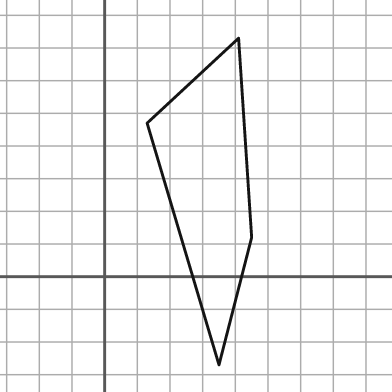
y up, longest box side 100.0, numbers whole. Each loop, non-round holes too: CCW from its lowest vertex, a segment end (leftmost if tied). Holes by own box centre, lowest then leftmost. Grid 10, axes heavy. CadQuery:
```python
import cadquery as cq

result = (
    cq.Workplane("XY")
    .moveTo(35.0, -27.0)
    .lineTo(45.0, 12.0)
    .lineTo(41.0, 73.0)
    .lineTo(13.0, 47.0)
    .close()
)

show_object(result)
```